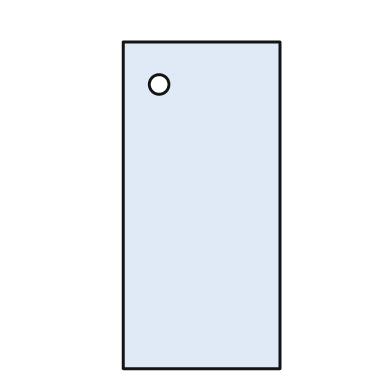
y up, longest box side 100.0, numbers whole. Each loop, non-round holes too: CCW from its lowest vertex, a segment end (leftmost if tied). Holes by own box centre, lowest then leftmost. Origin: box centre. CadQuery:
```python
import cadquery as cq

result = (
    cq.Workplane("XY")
    .moveTo(-24.0, -50.0)
    .lineTo(24.0, -50.0)
    .lineTo(24.0, 50.0)
    .lineTo(-24.0, 50.0)
    .close()
    .moveTo(-13.0, 37.0)
    .circle(3.0)
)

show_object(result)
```